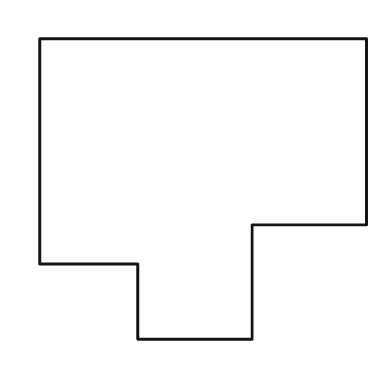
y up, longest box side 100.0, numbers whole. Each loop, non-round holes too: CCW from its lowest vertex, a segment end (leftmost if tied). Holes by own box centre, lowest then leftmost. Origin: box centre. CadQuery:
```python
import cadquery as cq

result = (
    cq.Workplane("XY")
    .moveTo(-20.0, -46.0)
    .lineTo(15.0, -46.0)
    .lineTo(15.0, -11.0)
    .lineTo(50.0, -11.0)
    .lineTo(50.0, 46.0)
    .lineTo(-50.0, 46.0)
    .lineTo(-50.0, -23.0)
    .lineTo(-20.0, -23.0)
    .close()
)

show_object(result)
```